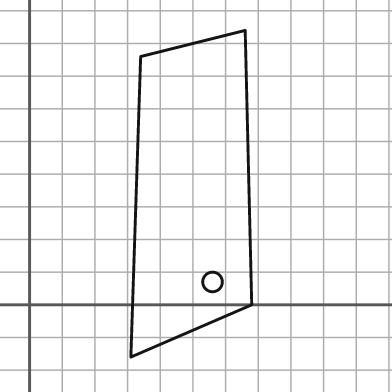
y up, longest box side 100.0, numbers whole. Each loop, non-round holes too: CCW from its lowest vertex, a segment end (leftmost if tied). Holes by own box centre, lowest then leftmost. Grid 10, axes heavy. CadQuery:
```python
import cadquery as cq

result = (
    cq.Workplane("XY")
    .moveTo(31.0, -16.0)
    .lineTo(68.0, 0.0)
    .lineTo(66.0, 84.0)
    .lineTo(34.0, 76.0)
    .close()
    .moveTo(56.0, 7.0)
    .circle(3.0)
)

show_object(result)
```